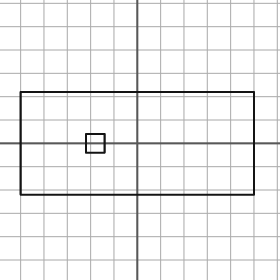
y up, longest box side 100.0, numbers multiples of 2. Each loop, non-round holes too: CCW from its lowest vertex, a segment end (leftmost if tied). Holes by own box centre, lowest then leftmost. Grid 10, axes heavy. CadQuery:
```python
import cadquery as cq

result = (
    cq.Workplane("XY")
    .moveTo(-50.0, -22.0)
    .lineTo(50.0, -22.0)
    .lineTo(50.0, 22.0)
    .lineTo(-50.0, 22.0)
    .close()
    .moveTo(-22.0, -4.0)
    .lineTo(-14.0, -4.0)
    .lineTo(-14.0, 4.0)
    .lineTo(-22.0, 4.0)
    .close()
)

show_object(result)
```